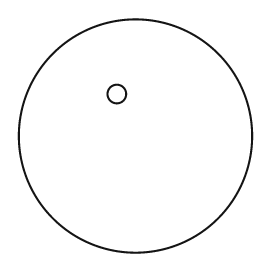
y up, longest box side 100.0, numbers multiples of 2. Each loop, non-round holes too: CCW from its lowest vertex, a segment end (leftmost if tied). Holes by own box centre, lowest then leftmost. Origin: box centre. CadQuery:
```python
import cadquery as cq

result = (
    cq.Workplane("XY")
    .moveTo(0.0, 0.0)
    .circle(50.0)
    .moveTo(-8.0, 18.0)
    .circle(4.0)
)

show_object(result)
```